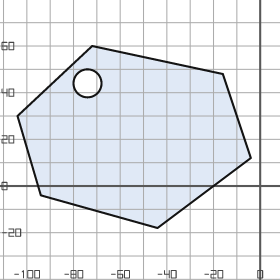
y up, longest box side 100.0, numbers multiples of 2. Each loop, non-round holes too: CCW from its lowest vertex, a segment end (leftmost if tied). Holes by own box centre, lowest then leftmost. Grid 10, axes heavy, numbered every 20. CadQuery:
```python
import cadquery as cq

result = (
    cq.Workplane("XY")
    .moveTo(-44.0, -18.0)
    .lineTo(-4.0, 12.0)
    .lineTo(-16.0, 48.0)
    .lineTo(-72.0, 60.0)
    .lineTo(-104.0, 30.0)
    .lineTo(-94.0, -4.0)
    .close()
    .moveTo(-74.0, 44.0)
    .circle(6.0)
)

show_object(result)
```